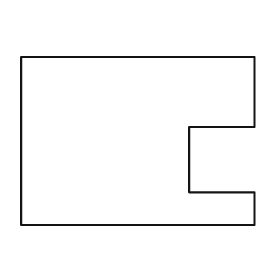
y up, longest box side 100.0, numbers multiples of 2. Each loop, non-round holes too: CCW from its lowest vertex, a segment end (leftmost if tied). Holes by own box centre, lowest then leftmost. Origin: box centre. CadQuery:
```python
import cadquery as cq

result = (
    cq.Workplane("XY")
    .moveTo(-50.0, -36.0)
    .lineTo(50.0, -36.0)
    .lineTo(50.0, -22.0)
    .lineTo(22.0, -22.0)
    .lineTo(22.0, 6.0)
    .lineTo(50.0, 6.0)
    .lineTo(50.0, 36.0)
    .lineTo(-50.0, 36.0)
    .close()
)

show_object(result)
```